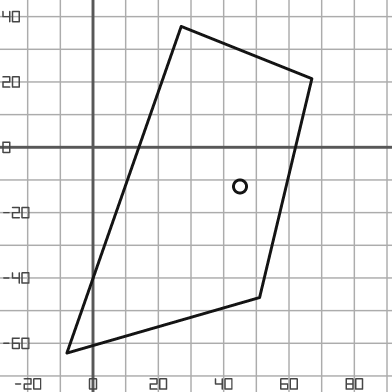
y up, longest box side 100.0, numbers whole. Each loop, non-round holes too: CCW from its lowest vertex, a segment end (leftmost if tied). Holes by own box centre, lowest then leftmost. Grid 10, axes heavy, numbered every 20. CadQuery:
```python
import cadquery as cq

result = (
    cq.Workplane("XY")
    .moveTo(-8.0, -63.0)
    .lineTo(51.0, -46.0)
    .lineTo(67.0, 21.0)
    .lineTo(27.0, 37.0)
    .close()
    .moveTo(45.0, -12.0)
    .circle(2.0)
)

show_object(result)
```